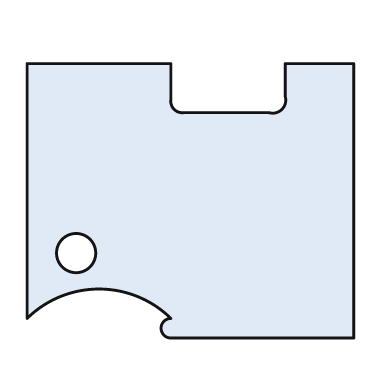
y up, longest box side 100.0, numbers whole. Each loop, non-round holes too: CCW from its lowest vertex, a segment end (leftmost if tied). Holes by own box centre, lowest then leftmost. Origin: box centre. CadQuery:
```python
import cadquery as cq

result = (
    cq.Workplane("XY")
    .moveTo(-6.0, -42.0)
    .lineTo(50.0, -42.0)
    .lineTo(50.0, 42.0)
    .lineTo(29.0, 42.0)
    .lineTo(29.0, 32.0)
    .threePointArc((28.0, 28.0), (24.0, 27.0))
    .lineTo(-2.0, 27.0)
    .threePointArc((-5.0, 28.0), (-6.0, 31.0))
    .lineTo(-6.0, 42.0)
    .lineTo(-50.0, 42.0)
    .lineTo(-50.0, -36.0)
    .threePointArc((-28.0, -27.0), (-6.0, -36.0))
    .threePointArc((-9.0, -39.0), (-6.0, -42.0))
    .close()
    .moveTo(-35.0, -16.0)
    .circle(6.0)
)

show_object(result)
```